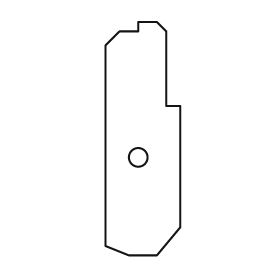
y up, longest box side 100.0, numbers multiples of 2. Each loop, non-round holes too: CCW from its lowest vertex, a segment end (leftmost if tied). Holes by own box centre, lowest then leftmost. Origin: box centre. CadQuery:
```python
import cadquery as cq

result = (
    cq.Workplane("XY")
    .moveTo(-6.0, -50.0)
    .lineTo(6.0, -50.0)
    .lineTo(16.0, -38.0)
    .lineTo(16.0, 14.0)
    .lineTo(10.0, 14.0)
    .lineTo(10.0, 46.0)
    .lineTo(6.0, 50.0)
    .lineTo(-2.0, 50.0)
    .lineTo(-2.0, 46.0)
    .lineTo(-10.0, 46.0)
    .lineTo(-16.0, 40.0)
    .lineTo(-16.0, -46.0)
    .close()
    .moveTo(-2.0, -8.0)
    .circle(4.0)
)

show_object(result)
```